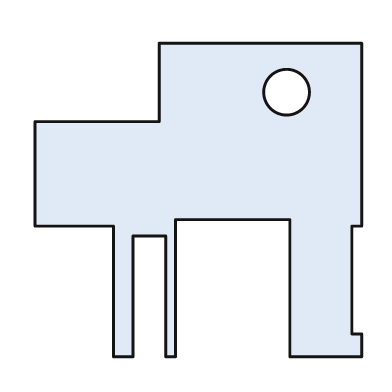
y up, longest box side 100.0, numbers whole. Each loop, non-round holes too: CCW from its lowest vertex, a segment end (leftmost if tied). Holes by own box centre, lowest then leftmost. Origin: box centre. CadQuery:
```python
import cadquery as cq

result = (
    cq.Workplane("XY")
    .moveTo(-26.0, -48.0)
    .lineTo(-20.0, -48.0)
    .lineTo(-20.0, -11.0)
    .lineTo(-10.0, -11.0)
    .lineTo(-10.0, -48.0)
    .lineTo(-7.0, -48.0)
    .lineTo(-7.0, -6.0)
    .lineTo(28.0, -6.0)
    .lineTo(28.0, -48.0)
    .lineTo(50.0, -48.0)
    .lineTo(50.0, -41.0)
    .lineTo(47.0, -41.0)
    .lineTo(47.0, -8.0)
    .lineTo(50.0, -8.0)
    .lineTo(50.0, 48.0)
    .lineTo(-12.0, 48.0)
    .lineTo(-12.0, 24.0)
    .lineTo(-50.0, 24.0)
    .lineTo(-50.0, -8.0)
    .lineTo(-26.0, -8.0)
    .close()
    .moveTo(27.0, 33.0)
    .circle(7.0)
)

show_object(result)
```